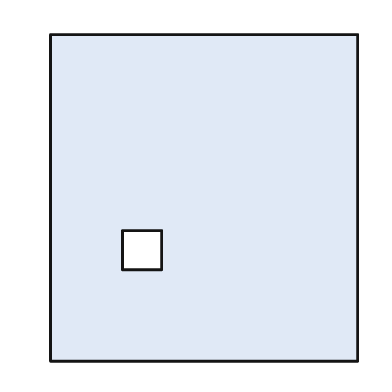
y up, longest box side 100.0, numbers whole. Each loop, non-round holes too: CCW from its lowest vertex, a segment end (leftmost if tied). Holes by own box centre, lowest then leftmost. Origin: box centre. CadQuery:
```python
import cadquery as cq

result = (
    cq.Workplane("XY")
    .moveTo(-47.0, -50.0)
    .lineTo(47.0, -50.0)
    .lineTo(47.0, 50.0)
    .lineTo(-47.0, 50.0)
    .close()
    .moveTo(-25.0, -22.0)
    .lineTo(-13.0, -22.0)
    .lineTo(-13.0, -10.0)
    .lineTo(-25.0, -10.0)
    .close()
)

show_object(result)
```